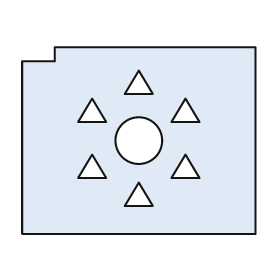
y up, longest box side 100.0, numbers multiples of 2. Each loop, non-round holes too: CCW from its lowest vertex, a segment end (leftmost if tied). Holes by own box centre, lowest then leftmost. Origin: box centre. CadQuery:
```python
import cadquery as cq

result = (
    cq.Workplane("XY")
    .moveTo(-50.0, -40.0)
    .lineTo(50.0, -40.0)
    .lineTo(50.0, 40.0)
    .lineTo(-36.0, 40.0)
    .lineTo(-36.0, 34.0)
    .lineTo(-50.0, 34.0)
    .close()
    .moveTo(-6.0, -28.0)
    .lineTo(6.0, -28.0)
    .lineTo(0.0, -18.0)
    .close()
    .moveTo(-26.0, -16.0)
    .lineTo(-14.0, -16.0)
    .lineTo(-20.0, -6.0)
    .close()
    .moveTo(14.0, -16.0)
    .lineTo(26.0, -16.0)
    .lineTo(20.0, -6.0)
    .close()
    .moveTo(0.0, 0.0)
    .circle(10.0)
    .moveTo(-26.0, 8.0)
    .lineTo(-14.0, 8.0)
    .lineTo(-20.0, 18.0)
    .close()
    .moveTo(14.0, 8.0)
    .lineTo(26.0, 8.0)
    .lineTo(20.0, 18.0)
    .close()
    .moveTo(-6.0, 20.0)
    .lineTo(6.0, 20.0)
    .lineTo(0.0, 30.0)
    .close()
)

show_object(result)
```